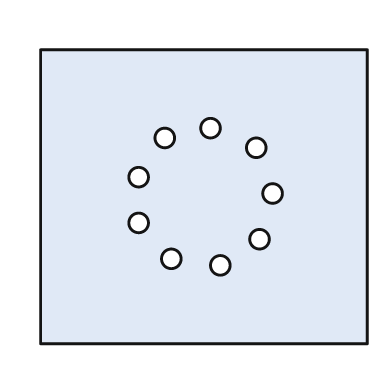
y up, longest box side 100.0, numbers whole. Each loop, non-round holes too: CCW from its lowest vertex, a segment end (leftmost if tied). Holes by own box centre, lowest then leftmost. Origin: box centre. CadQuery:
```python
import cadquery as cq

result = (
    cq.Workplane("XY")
    .moveTo(-50.0, -45.0)
    .lineTo(50.0, -45.0)
    .lineTo(50.0, 45.0)
    .lineTo(-50.0, 45.0)
    .close()
    .moveTo(5.0, -21.0)
    .circle(3.0)
    .moveTo(-10.0, -19.0)
    .circle(3.0)
    .moveTo(17.0, -13.0)
    .circle(3.0)
    .moveTo(-20.0, -8.0)
    .circle(3.0)
    .moveTo(21.0, 1.0)
    .circle(3.0)
    .moveTo(-20.0, 6.0)
    .circle(3.0)
    .moveTo(16.0, 15.0)
    .circle(3.0)
    .moveTo(-12.0, 18.0)
    .circle(3.0)
    .moveTo(2.0, 21.0)
    .circle(3.0)
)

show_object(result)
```